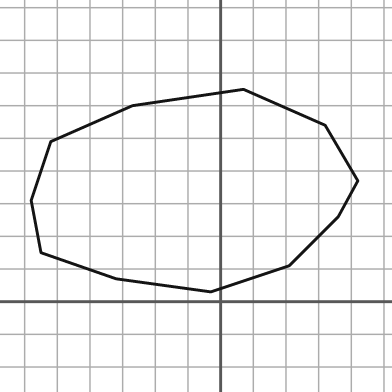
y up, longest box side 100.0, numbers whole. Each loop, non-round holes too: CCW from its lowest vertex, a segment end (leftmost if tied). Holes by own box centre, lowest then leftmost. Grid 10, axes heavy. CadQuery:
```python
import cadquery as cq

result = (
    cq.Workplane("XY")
    .moveTo(-3.0, 3.0)
    .lineTo(21.0, 11.0)
    .lineTo(36.0, 26.0)
    .lineTo(42.0, 37.0)
    .lineTo(32.0, 54.0)
    .lineTo(7.0, 65.0)
    .lineTo(-27.0, 60.0)
    .lineTo(-52.0, 49.0)
    .lineTo(-58.0, 31.0)
    .lineTo(-55.0, 15.0)
    .lineTo(-32.0, 7.0)
    .close()
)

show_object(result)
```